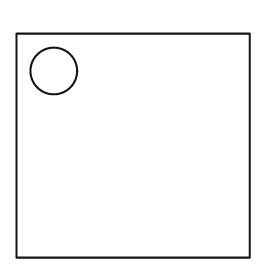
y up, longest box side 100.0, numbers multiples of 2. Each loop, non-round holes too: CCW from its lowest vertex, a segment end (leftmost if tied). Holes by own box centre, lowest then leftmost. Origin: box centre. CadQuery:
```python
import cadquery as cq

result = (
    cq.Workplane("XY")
    .moveTo(-50.0, -48.0)
    .lineTo(50.0, -48.0)
    .lineTo(50.0, 48.0)
    .lineTo(-50.0, 48.0)
    .close()
    .moveTo(-34.0, 32.0)
    .circle(10.0)
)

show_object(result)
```